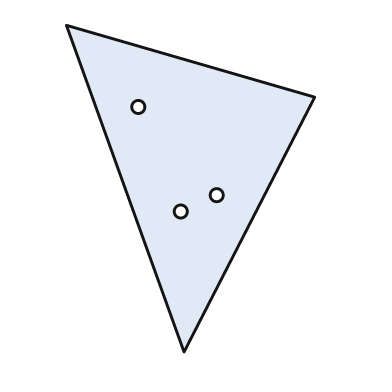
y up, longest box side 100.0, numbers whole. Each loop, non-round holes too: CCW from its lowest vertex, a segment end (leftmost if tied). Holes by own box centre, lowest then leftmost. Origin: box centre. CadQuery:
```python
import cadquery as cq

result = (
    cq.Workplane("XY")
    .moveTo(-2.0, -50.0)
    .lineTo(38.0, 28.0)
    .lineTo(-38.0, 50.0)
    .close()
    .moveTo(-3.0, -7.0)
    .circle(2.0)
    .moveTo(8.0, -2.0)
    .circle(2.0)
    .moveTo(-16.0, 25.0)
    .circle(2.0)
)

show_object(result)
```